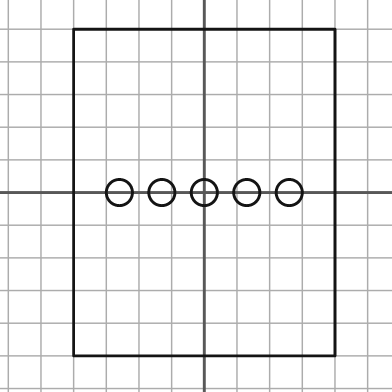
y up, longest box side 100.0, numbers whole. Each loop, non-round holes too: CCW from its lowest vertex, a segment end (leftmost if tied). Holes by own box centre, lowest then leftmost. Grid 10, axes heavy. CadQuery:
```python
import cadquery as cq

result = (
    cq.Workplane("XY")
    .moveTo(-40.0, -50.0)
    .lineTo(40.0, -50.0)
    .lineTo(40.0, 50.0)
    .lineTo(-40.0, 50.0)
    .close()
    .moveTo(-26.0, 0.0)
    .circle(4.0)
    .moveTo(-13.0, 0.0)
    .circle(4.0)
    .moveTo(0.0, 0.0)
    .circle(4.0)
    .moveTo(13.0, 0.0)
    .circle(4.0)
    .moveTo(26.0, 0.0)
    .circle(4.0)
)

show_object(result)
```